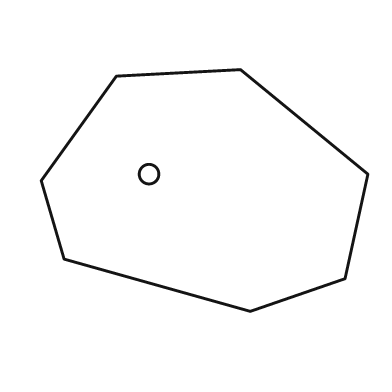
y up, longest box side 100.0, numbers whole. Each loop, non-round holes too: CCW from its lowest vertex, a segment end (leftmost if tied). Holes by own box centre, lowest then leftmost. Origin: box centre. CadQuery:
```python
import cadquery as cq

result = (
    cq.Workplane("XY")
    .moveTo(14.0, -37.0)
    .lineTo(43.0, -27.0)
    .lineTo(50.0, 5.0)
    .lineTo(11.0, 37.0)
    .lineTo(-27.0, 35.0)
    .lineTo(-50.0, 3.0)
    .lineTo(-43.0, -21.0)
    .close()
    .moveTo(-17.0, 5.0)
    .circle(3.0)
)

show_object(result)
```